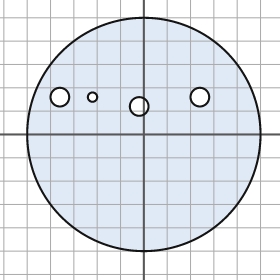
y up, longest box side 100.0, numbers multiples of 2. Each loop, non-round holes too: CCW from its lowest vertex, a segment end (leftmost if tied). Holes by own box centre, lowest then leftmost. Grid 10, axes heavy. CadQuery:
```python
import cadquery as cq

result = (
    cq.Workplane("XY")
    .moveTo(0.0, 0.0)
    .circle(50.0)
    .moveTo(-2.0, 12.0)
    .circle(4.0)
    .moveTo(-36.0, 16.0)
    .circle(4.0)
    .moveTo(-22.0, 16.0)
    .circle(2.0)
    .moveTo(24.0, 16.0)
    .circle(4.0)
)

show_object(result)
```